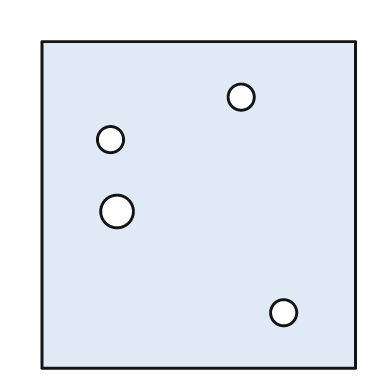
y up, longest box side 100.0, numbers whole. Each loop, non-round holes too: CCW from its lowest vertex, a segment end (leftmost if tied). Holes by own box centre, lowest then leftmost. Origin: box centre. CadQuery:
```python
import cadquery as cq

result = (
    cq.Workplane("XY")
    .moveTo(-48.0, -50.0)
    .lineTo(48.0, -50.0)
    .lineTo(48.0, 50.0)
    .lineTo(-48.0, 50.0)
    .close()
    .moveTo(26.0, -33.0)
    .circle(4.0)
    .moveTo(-25.0, -2.0)
    .circle(5.0)
    .moveTo(-27.0, 20.0)
    .circle(4.0)
    .moveTo(13.0, 33.0)
    .circle(4.0)
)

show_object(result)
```